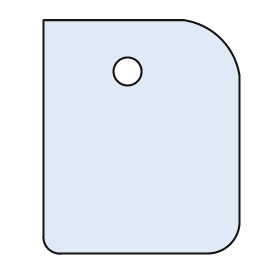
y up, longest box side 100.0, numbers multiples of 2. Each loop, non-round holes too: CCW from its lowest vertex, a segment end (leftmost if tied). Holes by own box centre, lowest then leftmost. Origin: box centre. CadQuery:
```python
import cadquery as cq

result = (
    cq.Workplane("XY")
    .moveTo(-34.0, -50.0)
    .lineTo(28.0, -50.0)
    .threePointArc((38.0, -46.0), (42.0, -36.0))
    .lineTo(42.0, 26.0)
    .threePointArc((34.0, 42.0), (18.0, 50.0))
    .lineTo(-42.0, 50.0)
    .lineTo(-42.0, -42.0)
    .threePointArc((-40.0, -48.0), (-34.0, -50.0))
    .close()
    .moveTo(-6.0, 28.0)
    .circle(6.0)
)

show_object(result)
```